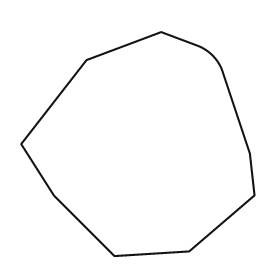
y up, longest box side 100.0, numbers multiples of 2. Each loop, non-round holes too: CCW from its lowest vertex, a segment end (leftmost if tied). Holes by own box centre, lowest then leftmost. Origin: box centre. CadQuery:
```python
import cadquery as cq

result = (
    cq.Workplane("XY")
    .moveTo(-10.0, -48.0)
    .lineTo(22.0, -46.0)
    .lineTo(50.0, -22.0)
    .lineTo(48.0, -4.0)
    .lineTo(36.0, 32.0)
    .threePointArc((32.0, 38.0), (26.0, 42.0))
    .lineTo(10.0, 48.0)
    .lineTo(-22.0, 36.0)
    .lineTo(-50.0, 0.0)
    .lineTo(-36.0, -22.0)
    .close()
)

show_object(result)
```